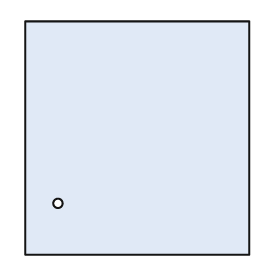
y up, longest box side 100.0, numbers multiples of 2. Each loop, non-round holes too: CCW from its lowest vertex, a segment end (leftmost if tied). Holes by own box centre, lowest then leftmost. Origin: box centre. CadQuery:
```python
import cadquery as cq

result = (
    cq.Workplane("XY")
    .moveTo(-48.0, -50.0)
    .lineTo(48.0, -50.0)
    .lineTo(48.0, 50.0)
    .lineTo(-48.0, 50.0)
    .close()
    .moveTo(-34.0, -28.0)
    .circle(2.0)
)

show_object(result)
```